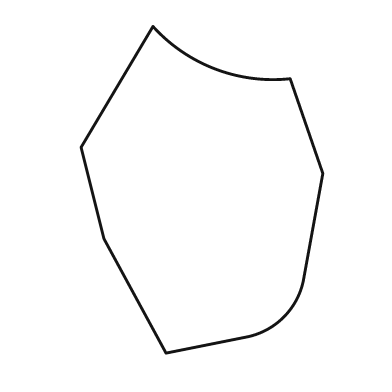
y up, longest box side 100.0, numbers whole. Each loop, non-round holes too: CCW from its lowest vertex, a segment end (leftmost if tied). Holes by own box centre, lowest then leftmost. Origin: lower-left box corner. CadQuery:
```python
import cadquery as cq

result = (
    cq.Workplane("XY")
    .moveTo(26.0, 0.0)
    .lineTo(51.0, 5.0)
    .threePointArc((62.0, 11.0), (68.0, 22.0))
    .lineTo(74.0, 55.0)
    .lineTo(64.0, 84.0)
    .threePointArc((41.0, 87.0), (22.0, 100.0))
    .lineTo(0.0, 63.0)
    .lineTo(7.0, 35.0)
    .close()
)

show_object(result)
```